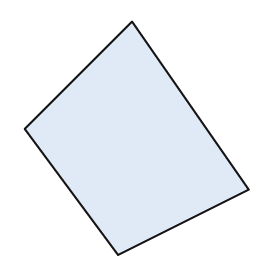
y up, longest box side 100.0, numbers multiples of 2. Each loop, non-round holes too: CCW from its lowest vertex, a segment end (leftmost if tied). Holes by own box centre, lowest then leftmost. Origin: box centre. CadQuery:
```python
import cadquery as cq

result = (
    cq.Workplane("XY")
    .moveTo(-8.0, -50.0)
    .lineTo(48.0, -22.0)
    .lineTo(-2.0, 50.0)
    .lineTo(-48.0, 4.0)
    .close()
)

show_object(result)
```